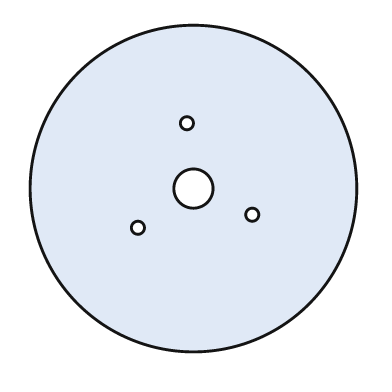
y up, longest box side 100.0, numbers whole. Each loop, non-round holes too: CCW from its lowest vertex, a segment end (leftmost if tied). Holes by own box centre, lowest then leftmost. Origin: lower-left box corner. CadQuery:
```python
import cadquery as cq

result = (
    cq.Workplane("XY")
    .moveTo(50.0, 50.0)
    .circle(50.0)
    .moveTo(33.0, 38.0)
    .circle(2.0)
    .moveTo(68.0, 42.0)
    .circle(2.0)
    .moveTo(50.0, 50.0)
    .circle(6.0)
    .moveTo(48.0, 70.0)
    .circle(2.0)
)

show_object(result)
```